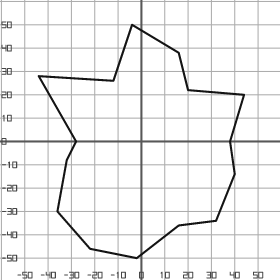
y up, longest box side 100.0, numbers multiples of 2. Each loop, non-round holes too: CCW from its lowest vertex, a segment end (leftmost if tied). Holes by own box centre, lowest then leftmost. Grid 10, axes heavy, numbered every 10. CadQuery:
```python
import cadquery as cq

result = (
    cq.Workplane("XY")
    .moveTo(-2.0, -50.0)
    .lineTo(16.0, -36.0)
    .lineTo(32.0, -34.0)
    .lineTo(40.0, -14.0)
    .lineTo(38.0, 0.0)
    .lineTo(44.0, 20.0)
    .lineTo(20.0, 22.0)
    .lineTo(16.0, 38.0)
    .lineTo(-4.0, 50.0)
    .lineTo(-12.0, 26.0)
    .lineTo(-44.0, 28.0)
    .lineTo(-28.0, 0.0)
    .lineTo(-32.0, -8.0)
    .lineTo(-36.0, -30.0)
    .lineTo(-22.0, -46.0)
    .close()
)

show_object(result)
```